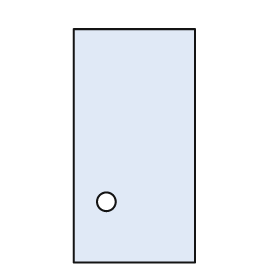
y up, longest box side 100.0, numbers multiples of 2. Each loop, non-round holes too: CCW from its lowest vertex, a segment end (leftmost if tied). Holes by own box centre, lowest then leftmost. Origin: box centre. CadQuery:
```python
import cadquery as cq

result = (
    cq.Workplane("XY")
    .moveTo(-26.0, -50.0)
    .lineTo(26.0, -50.0)
    .lineTo(26.0, 50.0)
    .lineTo(-26.0, 50.0)
    .close()
    .moveTo(-12.0, -24.0)
    .circle(4.0)
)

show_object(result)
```